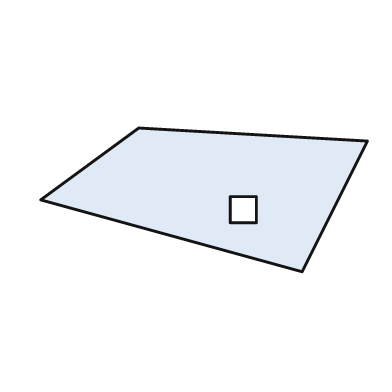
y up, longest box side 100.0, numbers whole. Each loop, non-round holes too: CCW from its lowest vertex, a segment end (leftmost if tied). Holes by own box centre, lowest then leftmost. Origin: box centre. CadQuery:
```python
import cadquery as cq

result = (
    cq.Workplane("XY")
    .moveTo(30.0, -22.0)
    .lineTo(50.0, 18.0)
    .lineTo(-20.0, 22.0)
    .lineTo(-50.0, 0.0)
    .close()
    .moveTo(8.0, -7.0)
    .lineTo(16.0, -7.0)
    .lineTo(16.0, 1.0)
    .lineTo(8.0, 1.0)
    .close()
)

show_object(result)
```